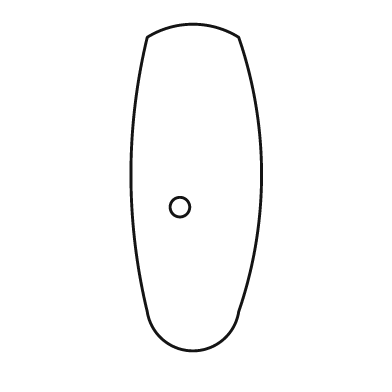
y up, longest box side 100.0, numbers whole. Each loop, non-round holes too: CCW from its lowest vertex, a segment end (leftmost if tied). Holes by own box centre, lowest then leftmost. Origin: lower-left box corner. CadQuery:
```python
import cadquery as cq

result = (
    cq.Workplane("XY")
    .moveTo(5.0, 12.0)
    .threePointArc((19.0, 0.0), (33.0, 12.0))
    .threePointArc((40.0, 54.0), (33.0, 96.0))
    .threePointArc((19.0, 100.0), (5.0, 96.0))
    .threePointArc((0.0, 54.0), (5.0, 12.0))
    .close()
    .moveTo(15.0, 44.0)
    .circle(3.0)
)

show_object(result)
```